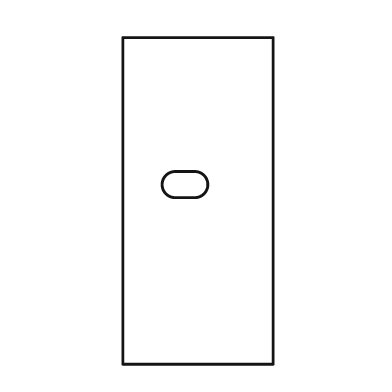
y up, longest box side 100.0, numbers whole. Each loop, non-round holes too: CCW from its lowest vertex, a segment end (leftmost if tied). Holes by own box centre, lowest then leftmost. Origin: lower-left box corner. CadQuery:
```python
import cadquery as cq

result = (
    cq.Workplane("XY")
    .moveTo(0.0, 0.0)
    .lineTo(46.0, 0.0)
    .lineTo(46.0, 100.0)
    .lineTo(0.0, 100.0)
    .close()
    .moveTo(16.0, 51.0)
    .lineTo(22.0, 51.0)
    .threePointArc((26.0, 55.0), (22.0, 59.0))
    .lineTo(16.0, 59.0)
    .threePointArc((12.0, 55.0), (16.0, 51.0))
    .close()
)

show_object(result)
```